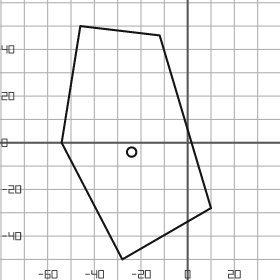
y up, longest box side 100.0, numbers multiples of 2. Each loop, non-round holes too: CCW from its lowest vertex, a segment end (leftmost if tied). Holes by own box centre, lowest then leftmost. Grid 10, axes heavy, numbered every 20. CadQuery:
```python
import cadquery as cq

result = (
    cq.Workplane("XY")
    .moveTo(-28.0, -50.0)
    .lineTo(10.0, -28.0)
    .lineTo(-12.0, 46.0)
    .lineTo(-46.0, 50.0)
    .lineTo(-54.0, 0.0)
    .close()
    .moveTo(-24.0, -4.0)
    .circle(2.0)
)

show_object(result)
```